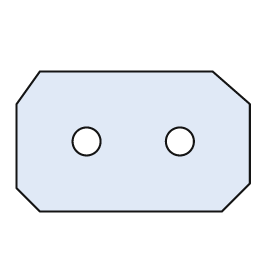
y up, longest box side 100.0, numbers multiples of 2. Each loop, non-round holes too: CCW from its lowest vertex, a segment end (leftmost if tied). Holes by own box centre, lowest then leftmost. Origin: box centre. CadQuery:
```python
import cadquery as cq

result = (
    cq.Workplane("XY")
    .moveTo(-40.0, -30.0)
    .lineTo(38.0, -30.0)
    .lineTo(50.0, -18.0)
    .lineTo(50.0, 16.0)
    .lineTo(34.0, 30.0)
    .lineTo(-40.0, 30.0)
    .lineTo(-50.0, 16.0)
    .lineTo(-50.0, -20.0)
    .close()
    .moveTo(-20.0, 0.0)
    .circle(6.0)
    .moveTo(20.0, 0.0)
    .circle(6.0)
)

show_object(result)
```